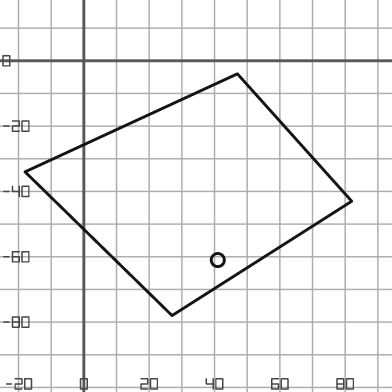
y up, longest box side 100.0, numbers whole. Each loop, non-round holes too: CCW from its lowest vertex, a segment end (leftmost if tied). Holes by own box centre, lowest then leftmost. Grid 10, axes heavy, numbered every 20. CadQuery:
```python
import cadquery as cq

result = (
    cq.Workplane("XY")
    .moveTo(27.0, -78.0)
    .lineTo(82.0, -43.0)
    .lineTo(47.0, -4.0)
    .lineTo(-18.0, -34.0)
    .close()
    .moveTo(41.0, -61.0)
    .circle(2.0)
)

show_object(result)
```